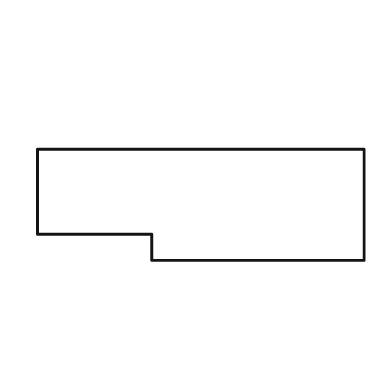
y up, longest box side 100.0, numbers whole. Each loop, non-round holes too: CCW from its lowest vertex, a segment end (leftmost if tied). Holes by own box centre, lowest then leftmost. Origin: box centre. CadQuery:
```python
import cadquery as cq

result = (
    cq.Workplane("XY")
    .moveTo(-15.0, -17.0)
    .lineTo(50.0, -17.0)
    .lineTo(50.0, 17.0)
    .lineTo(-50.0, 17.0)
    .lineTo(-50.0, -9.0)
    .lineTo(-15.0, -9.0)
    .close()
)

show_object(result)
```